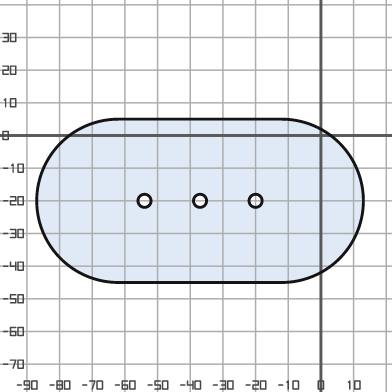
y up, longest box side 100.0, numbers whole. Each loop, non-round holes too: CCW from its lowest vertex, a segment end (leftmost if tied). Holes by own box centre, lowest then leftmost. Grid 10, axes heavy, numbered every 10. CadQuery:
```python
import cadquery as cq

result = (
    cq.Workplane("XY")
    .moveTo(-62.0, -45.0)
    .lineTo(-12.0, -45.0)
    .threePointArc((13.0, -20.0), (-12.0, 5.0))
    .lineTo(-62.0, 5.0)
    .threePointArc((-87.0, -20.0), (-62.0, -45.0))
    .close()
    .moveTo(-54.0, -20.0)
    .circle(2.0)
    .moveTo(-37.0, -20.0)
    .circle(2.0)
    .moveTo(-20.0, -20.0)
    .circle(2.0)
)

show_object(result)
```